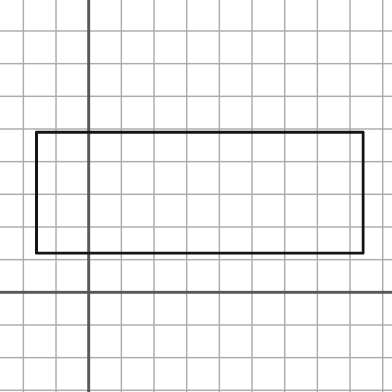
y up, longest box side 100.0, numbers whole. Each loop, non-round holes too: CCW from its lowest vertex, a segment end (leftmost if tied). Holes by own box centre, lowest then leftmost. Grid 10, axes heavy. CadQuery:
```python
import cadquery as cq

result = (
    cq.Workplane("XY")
    .moveTo(-16.0, 12.0)
    .lineTo(84.0, 12.0)
    .lineTo(84.0, 49.0)
    .lineTo(-16.0, 49.0)
    .close()
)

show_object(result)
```